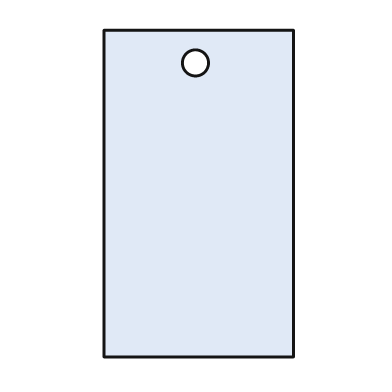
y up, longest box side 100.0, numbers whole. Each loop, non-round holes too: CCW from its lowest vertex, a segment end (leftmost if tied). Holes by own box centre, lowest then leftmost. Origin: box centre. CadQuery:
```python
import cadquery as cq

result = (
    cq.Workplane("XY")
    .moveTo(-29.0, -50.0)
    .lineTo(29.0, -50.0)
    .lineTo(29.0, 50.0)
    .lineTo(-29.0, 50.0)
    .close()
    .moveTo(-1.0, 40.0)
    .circle(4.0)
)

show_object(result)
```